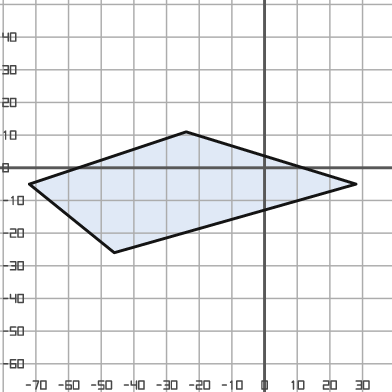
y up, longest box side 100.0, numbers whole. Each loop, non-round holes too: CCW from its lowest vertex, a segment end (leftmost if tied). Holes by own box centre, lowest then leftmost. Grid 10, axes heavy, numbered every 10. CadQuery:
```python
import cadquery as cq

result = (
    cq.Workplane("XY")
    .moveTo(-46.0, -26.0)
    .lineTo(28.0, -5.0)
    .lineTo(-24.0, 11.0)
    .lineTo(-72.0, -5.0)
    .close()
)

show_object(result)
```